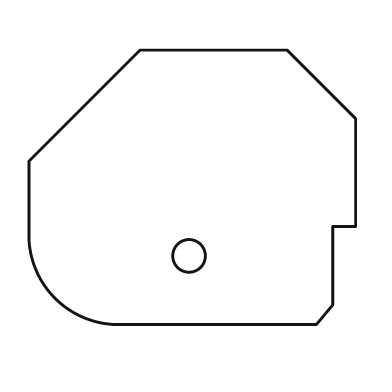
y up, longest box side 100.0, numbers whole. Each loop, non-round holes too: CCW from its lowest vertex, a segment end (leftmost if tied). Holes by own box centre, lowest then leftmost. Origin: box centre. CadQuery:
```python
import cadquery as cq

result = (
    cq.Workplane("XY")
    .moveTo(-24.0, -42.0)
    .lineTo(38.0, -42.0)
    .lineTo(43.0, -36.0)
    .lineTo(43.0, -12.0)
    .lineTo(50.0, -12.0)
    .lineTo(50.0, 21.0)
    .lineTo(29.0, 42.0)
    .lineTo(-16.0, 42.0)
    .lineTo(-50.0, 8.0)
    .lineTo(-50.0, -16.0)
    .threePointArc((-42.0, -34.0), (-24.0, -42.0))
    .close()
    .moveTo(-1.0, -21.0)
    .circle(5.0)
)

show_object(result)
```